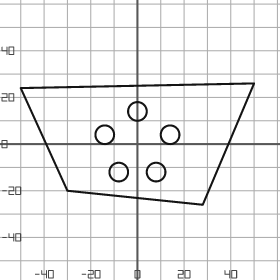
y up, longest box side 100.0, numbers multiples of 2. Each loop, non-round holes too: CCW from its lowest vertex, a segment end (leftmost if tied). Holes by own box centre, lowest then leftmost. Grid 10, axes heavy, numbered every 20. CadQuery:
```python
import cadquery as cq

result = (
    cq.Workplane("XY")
    .moveTo(28.0, -26.0)
    .lineTo(50.0, 26.0)
    .lineTo(-50.0, 24.0)
    .lineTo(-30.0, -20.0)
    .close()
    .moveTo(-8.0, -12.0)
    .circle(4.0)
    .moveTo(8.0, -12.0)
    .circle(4.0)
    .moveTo(-14.0, 4.0)
    .circle(4.0)
    .moveTo(14.0, 4.0)
    .circle(4.0)
    .moveTo(0.0, 14.0)
    .circle(4.0)
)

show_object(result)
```